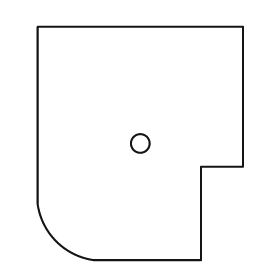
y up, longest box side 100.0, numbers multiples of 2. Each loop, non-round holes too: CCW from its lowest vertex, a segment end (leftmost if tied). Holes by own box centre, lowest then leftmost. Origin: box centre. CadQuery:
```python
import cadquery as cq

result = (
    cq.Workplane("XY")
    .moveTo(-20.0, -50.0)
    .lineTo(26.0, -50.0)
    .lineTo(26.0, -10.0)
    .lineTo(44.0, -10.0)
    .lineTo(44.0, 50.0)
    .lineTo(-44.0, 50.0)
    .lineTo(-44.0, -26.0)
    .threePointArc((-36.0, -42.0), (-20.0, -50.0))
    .close()
    .moveTo(0.0, 0.0)
    .circle(4.0)
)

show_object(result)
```